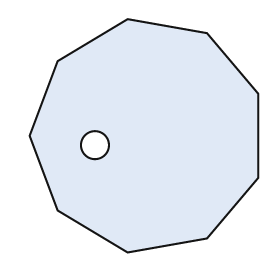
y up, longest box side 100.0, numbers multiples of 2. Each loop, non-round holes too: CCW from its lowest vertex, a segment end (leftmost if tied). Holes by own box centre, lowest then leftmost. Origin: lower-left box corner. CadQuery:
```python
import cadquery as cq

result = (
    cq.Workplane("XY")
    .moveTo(42.0, 0.0)
    .lineTo(76.0, 6.0)
    .lineTo(98.0, 32.0)
    .lineTo(98.0, 68.0)
    .lineTo(76.0, 94.0)
    .lineTo(42.0, 100.0)
    .lineTo(12.0, 82.0)
    .lineTo(0.0, 50.0)
    .lineTo(12.0, 18.0)
    .close()
    .moveTo(28.0, 46.0)
    .circle(6.0)
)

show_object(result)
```